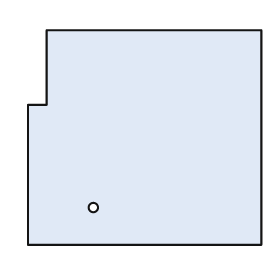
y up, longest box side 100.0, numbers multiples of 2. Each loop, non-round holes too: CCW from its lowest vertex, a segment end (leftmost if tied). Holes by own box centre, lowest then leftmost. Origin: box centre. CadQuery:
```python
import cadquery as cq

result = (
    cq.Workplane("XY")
    .moveTo(-50.0, -46.0)
    .lineTo(50.0, -46.0)
    .lineTo(50.0, 46.0)
    .lineTo(-42.0, 46.0)
    .lineTo(-42.0, 14.0)
    .lineTo(-50.0, 14.0)
    .close()
    .moveTo(-22.0, -30.0)
    .circle(2.0)
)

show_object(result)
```